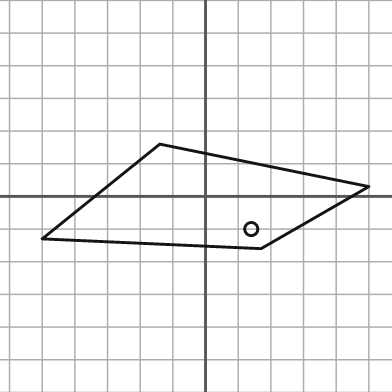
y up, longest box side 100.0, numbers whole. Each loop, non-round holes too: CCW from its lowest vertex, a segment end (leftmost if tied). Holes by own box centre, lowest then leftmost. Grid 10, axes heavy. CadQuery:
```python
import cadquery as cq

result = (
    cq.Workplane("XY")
    .moveTo(17.0, -16.0)
    .lineTo(50.0, 3.0)
    .lineTo(-14.0, 16.0)
    .lineTo(-50.0, -13.0)
    .close()
    .moveTo(14.0, -10.0)
    .circle(2.0)
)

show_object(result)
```